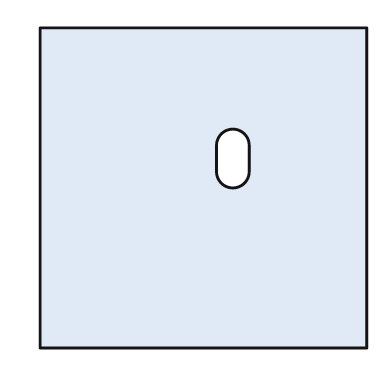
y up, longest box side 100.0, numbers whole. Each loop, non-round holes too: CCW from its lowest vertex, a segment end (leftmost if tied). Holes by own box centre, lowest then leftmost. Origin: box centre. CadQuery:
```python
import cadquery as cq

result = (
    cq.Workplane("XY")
    .moveTo(-50.0, -49.0)
    .lineTo(50.0, -49.0)
    .lineTo(50.0, 49.0)
    .lineTo(-50.0, 49.0)
    .close()
    .moveTo(4.0, 5.0)
    .threePointArc((9.0, 0.0), (14.0, 5.0))
    .lineTo(14.0, 13.0)
    .threePointArc((9.0, 18.0), (4.0, 13.0))
    .close()
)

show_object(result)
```